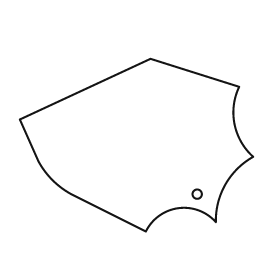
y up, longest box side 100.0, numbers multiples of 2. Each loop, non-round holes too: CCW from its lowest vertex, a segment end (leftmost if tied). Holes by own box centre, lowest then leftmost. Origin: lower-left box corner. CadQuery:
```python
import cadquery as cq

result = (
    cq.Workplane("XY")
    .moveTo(54.0, 0.0)
    .threePointArc((68.0, 10.0), (84.0, 4.0))
    .threePointArc((88.0, 20.0), (100.0, 32.0))
    .threePointArc((92.0, 46.0), (94.0, 62.0))
    .lineTo(56.0, 74.0)
    .lineTo(0.0, 48.0)
    .lineTo(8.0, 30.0)
    .threePointArc((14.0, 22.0), (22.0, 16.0))
    .close()
    .moveTo(76.0, 16.0)
    .circle(2.0)
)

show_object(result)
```